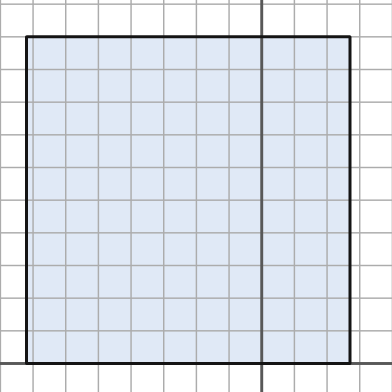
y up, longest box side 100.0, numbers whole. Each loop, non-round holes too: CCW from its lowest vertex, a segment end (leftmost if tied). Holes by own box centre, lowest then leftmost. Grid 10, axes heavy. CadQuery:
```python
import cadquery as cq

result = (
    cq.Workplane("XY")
    .moveTo(-72.0, 0.0)
    .lineTo(27.0, 0.0)
    .lineTo(27.0, 100.0)
    .lineTo(-72.0, 100.0)
    .close()
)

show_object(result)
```